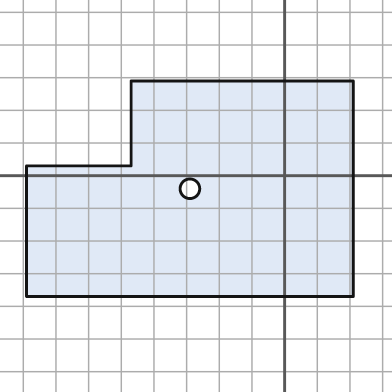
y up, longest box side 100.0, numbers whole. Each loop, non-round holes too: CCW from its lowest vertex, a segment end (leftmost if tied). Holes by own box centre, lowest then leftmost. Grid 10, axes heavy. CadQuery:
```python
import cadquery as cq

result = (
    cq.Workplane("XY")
    .moveTo(-79.0, -37.0)
    .lineTo(21.0, -37.0)
    .lineTo(21.0, 29.0)
    .lineTo(-47.0, 29.0)
    .lineTo(-47.0, 3.0)
    .lineTo(-79.0, 3.0)
    .close()
    .moveTo(-29.0, -4.0)
    .circle(3.0)
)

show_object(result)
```